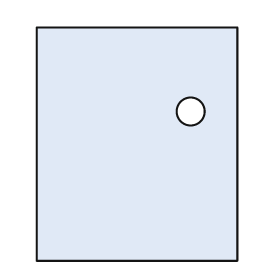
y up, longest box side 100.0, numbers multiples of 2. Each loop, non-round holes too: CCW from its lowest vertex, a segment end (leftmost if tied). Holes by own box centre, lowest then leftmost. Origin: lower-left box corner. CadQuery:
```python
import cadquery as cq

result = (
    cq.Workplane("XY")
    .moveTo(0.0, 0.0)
    .lineTo(86.0, 0.0)
    .lineTo(86.0, 100.0)
    .lineTo(0.0, 100.0)
    .close()
    .moveTo(66.0, 64.0)
    .circle(6.0)
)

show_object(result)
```